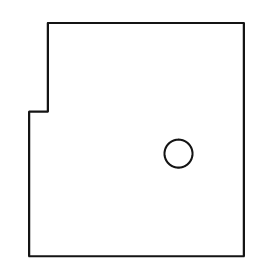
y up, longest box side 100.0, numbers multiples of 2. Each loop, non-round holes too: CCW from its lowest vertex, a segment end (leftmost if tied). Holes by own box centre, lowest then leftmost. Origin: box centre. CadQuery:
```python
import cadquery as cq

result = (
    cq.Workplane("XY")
    .moveTo(-46.0, -50.0)
    .lineTo(46.0, -50.0)
    .lineTo(46.0, 50.0)
    .lineTo(-38.0, 50.0)
    .lineTo(-38.0, 12.0)
    .lineTo(-46.0, 12.0)
    .close()
    .moveTo(18.0, -6.0)
    .circle(6.0)
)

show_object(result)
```